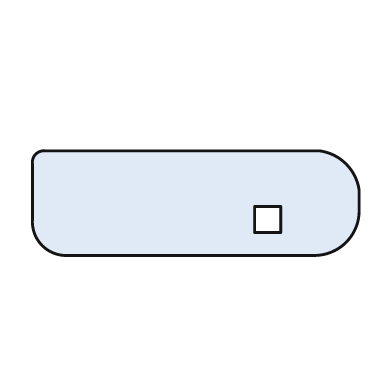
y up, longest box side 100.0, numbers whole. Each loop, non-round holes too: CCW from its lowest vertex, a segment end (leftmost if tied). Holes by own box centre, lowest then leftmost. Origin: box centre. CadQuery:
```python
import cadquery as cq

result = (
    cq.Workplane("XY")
    .moveTo(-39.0, -16.0)
    .lineTo(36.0, -16.0)
    .threePointArc((46.0, -12.0), (50.0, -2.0))
    .lineTo(50.0, 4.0)
    .threePointArc((46.0, 12.0), (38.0, 16.0))
    .lineTo(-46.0, 16.0)
    .threePointArc((-49.0, 15.0), (-50.0, 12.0))
    .lineTo(-50.0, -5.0)
    .threePointArc((-47.0, -13.0), (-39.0, -16.0))
    .close()
    .moveTo(18.0, -9.0)
    .lineTo(26.0, -9.0)
    .lineTo(26.0, -1.0)
    .lineTo(18.0, -1.0)
    .close()
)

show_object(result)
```